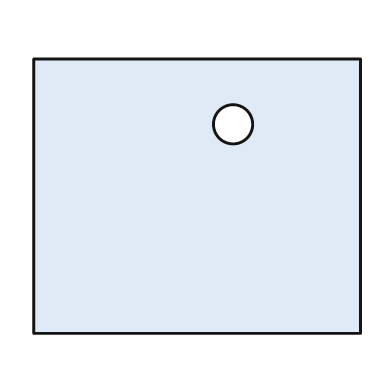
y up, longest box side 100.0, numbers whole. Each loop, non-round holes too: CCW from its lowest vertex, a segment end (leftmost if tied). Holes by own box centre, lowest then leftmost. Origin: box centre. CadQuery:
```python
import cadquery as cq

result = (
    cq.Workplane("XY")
    .moveTo(-50.0, -42.0)
    .lineTo(50.0, -42.0)
    .lineTo(50.0, 42.0)
    .lineTo(-50.0, 42.0)
    .close()
    .moveTo(11.0, 22.0)
    .circle(6.0)
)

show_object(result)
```